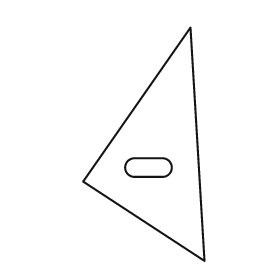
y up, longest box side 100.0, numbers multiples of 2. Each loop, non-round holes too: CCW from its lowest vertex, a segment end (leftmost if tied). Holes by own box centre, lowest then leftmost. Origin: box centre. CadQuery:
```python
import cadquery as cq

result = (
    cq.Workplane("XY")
    .moveTo(26.0, -50.0)
    .lineTo(20.0, 50.0)
    .lineTo(-26.0, -16.0)
    .close()
    .moveTo(-4.0, -14.0)
    .lineTo(8.0, -14.0)
    .threePointArc((12.0, -10.0), (8.0, -6.0))
    .lineTo(-4.0, -6.0)
    .threePointArc((-8.0, -10.0), (-4.0, -14.0))
    .close()
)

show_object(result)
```